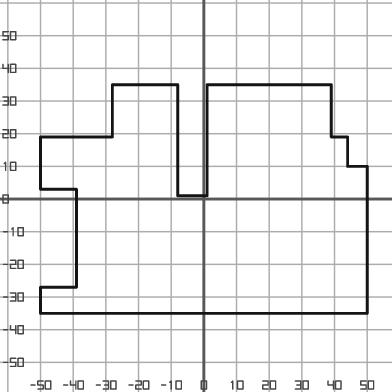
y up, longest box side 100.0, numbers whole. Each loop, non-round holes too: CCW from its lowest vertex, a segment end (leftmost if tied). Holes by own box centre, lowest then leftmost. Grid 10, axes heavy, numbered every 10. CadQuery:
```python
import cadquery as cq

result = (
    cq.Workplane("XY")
    .moveTo(-50.0, -35.0)
    .lineTo(50.0, -35.0)
    .lineTo(50.0, 10.0)
    .lineTo(44.0, 10.0)
    .lineTo(44.0, 19.0)
    .lineTo(39.0, 19.0)
    .lineTo(39.0, 35.0)
    .lineTo(1.0, 35.0)
    .lineTo(1.0, 1.0)
    .lineTo(-8.0, 1.0)
    .lineTo(-8.0, 35.0)
    .lineTo(-28.0, 35.0)
    .lineTo(-28.0, 19.0)
    .lineTo(-50.0, 19.0)
    .lineTo(-50.0, 3.0)
    .lineTo(-39.0, 3.0)
    .lineTo(-39.0, -27.0)
    .lineTo(-50.0, -27.0)
    .close()
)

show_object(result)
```